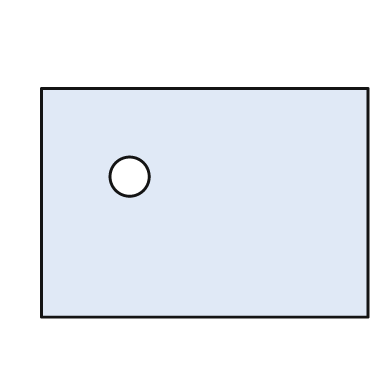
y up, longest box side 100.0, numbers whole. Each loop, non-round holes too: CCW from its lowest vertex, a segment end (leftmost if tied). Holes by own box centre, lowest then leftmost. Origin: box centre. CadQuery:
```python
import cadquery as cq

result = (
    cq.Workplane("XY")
    .moveTo(-50.0, -35.0)
    .lineTo(50.0, -35.0)
    .lineTo(50.0, 35.0)
    .lineTo(-50.0, 35.0)
    .close()
    .moveTo(-23.0, 8.0)
    .circle(6.0)
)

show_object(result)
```